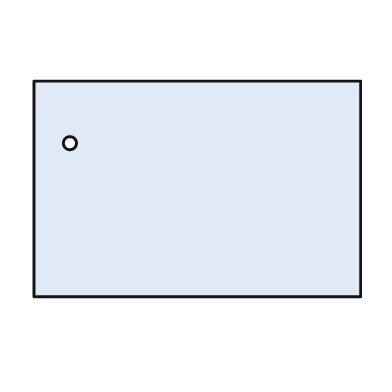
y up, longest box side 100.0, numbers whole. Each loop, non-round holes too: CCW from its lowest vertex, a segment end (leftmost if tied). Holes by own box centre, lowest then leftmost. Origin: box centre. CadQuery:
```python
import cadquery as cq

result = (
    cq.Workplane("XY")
    .moveTo(-50.0, -33.0)
    .lineTo(50.0, -33.0)
    .lineTo(50.0, 33.0)
    .lineTo(-50.0, 33.0)
    .close()
    .moveTo(-39.0, 14.0)
    .circle(2.0)
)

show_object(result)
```